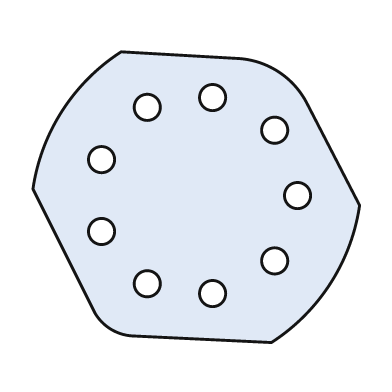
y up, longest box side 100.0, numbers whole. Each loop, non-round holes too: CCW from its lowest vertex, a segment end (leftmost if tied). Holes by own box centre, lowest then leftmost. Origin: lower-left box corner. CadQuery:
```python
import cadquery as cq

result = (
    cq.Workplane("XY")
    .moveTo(73.0, 0.0)
    .threePointArc((91.0, 18.0), (100.0, 42.0))
    .lineTo(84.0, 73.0)
    .threePointArc((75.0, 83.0), (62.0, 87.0))
    .lineTo(27.0, 89.0)
    .threePointArc((9.0, 71.0), (0.0, 47.0))
    .lineTo(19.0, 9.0)
    .threePointArc((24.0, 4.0), (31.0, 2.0))
    .close()
    .moveTo(55.0, 15.0)
    .circle(4.0)
    .moveTo(35.0, 18.0)
    .circle(4.0)
    .moveTo(74.0, 25.0)
    .circle(4.0)
    .moveTo(21.0, 34.0)
    .circle(4.0)
    .moveTo(81.0, 45.0)
    .circle(4.0)
    .moveTo(21.0, 56.0)
    .circle(4.0)
    .moveTo(74.0, 65.0)
    .circle(4.0)
    .moveTo(35.0, 72.0)
    .circle(4.0)
    .moveTo(55.0, 75.0)
    .circle(4.0)
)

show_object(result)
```